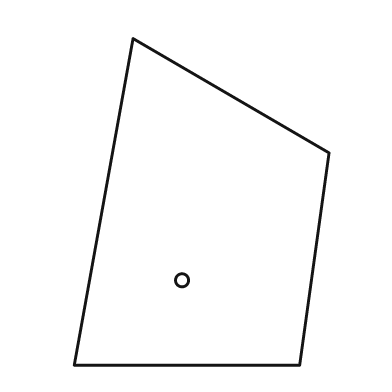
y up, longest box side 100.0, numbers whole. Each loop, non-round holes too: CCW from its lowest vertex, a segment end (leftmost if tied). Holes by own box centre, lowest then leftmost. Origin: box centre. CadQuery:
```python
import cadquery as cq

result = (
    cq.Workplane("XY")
    .moveTo(-39.0, -50.0)
    .lineTo(30.0, -50.0)
    .lineTo(39.0, 15.0)
    .lineTo(-21.0, 50.0)
    .close()
    .moveTo(-6.0, -24.0)
    .circle(2.0)
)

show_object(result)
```